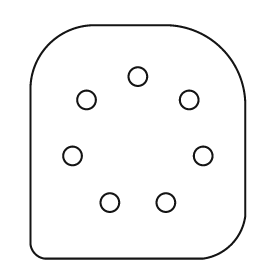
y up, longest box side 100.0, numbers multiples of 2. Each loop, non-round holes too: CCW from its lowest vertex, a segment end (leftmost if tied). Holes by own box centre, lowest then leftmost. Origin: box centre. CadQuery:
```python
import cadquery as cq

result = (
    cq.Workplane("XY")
    .moveTo(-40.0, -50.0)
    .lineTo(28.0, -50.0)
    .threePointArc((40.0, -44.0), (46.0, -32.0))
    .lineTo(46.0, 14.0)
    .threePointArc((36.0, 40.0), (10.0, 50.0))
    .lineTo(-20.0, 50.0)
    .threePointArc((-38.0, 42.0), (-46.0, 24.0))
    .lineTo(-46.0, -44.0)
    .threePointArc((-44.0, -48.0), (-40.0, -50.0))
    .close()
    .moveTo(-12.0, -26.0)
    .circle(4.0)
    .moveTo(12.0, -26.0)
    .circle(4.0)
    .moveTo(-28.0, -6.0)
    .circle(4.0)
    .moveTo(28.0, -6.0)
    .circle(4.0)
    .moveTo(-22.0, 18.0)
    .circle(4.0)
    .moveTo(22.0, 18.0)
    .circle(4.0)
    .moveTo(0.0, 28.0)
    .circle(4.0)
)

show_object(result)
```